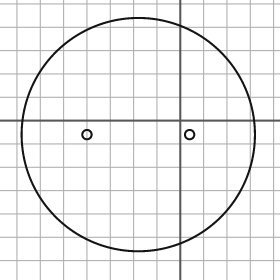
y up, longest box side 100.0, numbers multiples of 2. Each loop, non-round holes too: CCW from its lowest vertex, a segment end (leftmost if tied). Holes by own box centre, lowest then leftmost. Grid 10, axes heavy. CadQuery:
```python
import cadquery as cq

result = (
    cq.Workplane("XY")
    .moveTo(-18.0, -6.0)
    .circle(50.0)
    .moveTo(-40.0, -6.0)
    .circle(2.0)
    .moveTo(4.0, -6.0)
    .circle(2.0)
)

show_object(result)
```